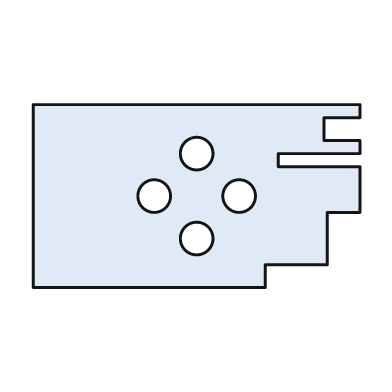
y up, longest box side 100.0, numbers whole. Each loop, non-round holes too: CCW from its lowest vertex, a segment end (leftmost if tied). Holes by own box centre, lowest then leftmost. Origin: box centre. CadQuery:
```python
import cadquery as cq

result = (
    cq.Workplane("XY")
    .moveTo(-50.0, -28.0)
    .lineTo(21.0, -28.0)
    .lineTo(21.0, -21.0)
    .lineTo(40.0, -21.0)
    .lineTo(40.0, -5.0)
    .lineTo(50.0, -5.0)
    .lineTo(50.0, 9.0)
    .lineTo(25.0, 9.0)
    .lineTo(25.0, 13.0)
    .lineTo(50.0, 13.0)
    .lineTo(50.0, 17.0)
    .lineTo(39.0, 17.0)
    .lineTo(39.0, 24.0)
    .lineTo(50.0, 24.0)
    .lineTo(50.0, 28.0)
    .lineTo(-50.0, 28.0)
    .close()
    .moveTo(0.0, -13.0)
    .circle(5.0)
    .moveTo(-13.0, 0.0)
    .circle(5.0)
    .moveTo(13.0, 0.0)
    .circle(5.0)
    .moveTo(0.0, 13.0)
    .circle(5.0)
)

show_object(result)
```